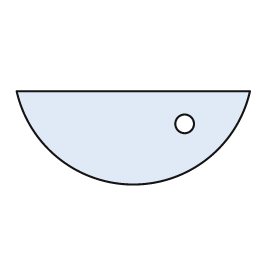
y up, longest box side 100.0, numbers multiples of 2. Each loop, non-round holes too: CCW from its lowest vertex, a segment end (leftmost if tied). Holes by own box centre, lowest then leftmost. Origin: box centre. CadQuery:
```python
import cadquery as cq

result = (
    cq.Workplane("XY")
    .moveTo(-50.0, 20.0)
    .threePointArc((0.0, -20.0), (50.0, 20.0))
    .close()
    .moveTo(22.0, 6.0)
    .circle(4.0)
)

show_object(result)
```